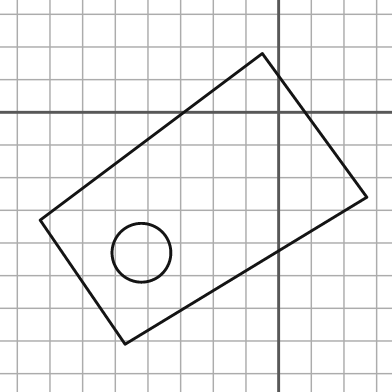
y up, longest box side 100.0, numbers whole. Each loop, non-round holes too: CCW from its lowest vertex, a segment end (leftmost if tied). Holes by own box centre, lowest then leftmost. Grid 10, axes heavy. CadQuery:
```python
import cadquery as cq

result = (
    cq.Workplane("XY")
    .moveTo(-47.0, -71.0)
    .lineTo(27.0, -26.0)
    .lineTo(-5.0, 18.0)
    .lineTo(-73.0, -33.0)
    .close()
    .moveTo(-42.0, -43.0)
    .circle(9.0)
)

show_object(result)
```